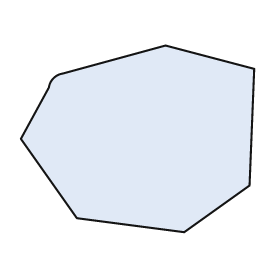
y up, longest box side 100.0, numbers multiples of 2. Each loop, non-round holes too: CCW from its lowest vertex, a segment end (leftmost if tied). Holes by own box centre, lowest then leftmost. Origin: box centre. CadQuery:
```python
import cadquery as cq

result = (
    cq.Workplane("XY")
    .moveTo(20.0, -40.0)
    .lineTo(48.0, -20.0)
    .lineTo(50.0, 30.0)
    .lineTo(12.0, 40.0)
    .lineTo(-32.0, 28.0)
    .threePointArc((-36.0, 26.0), (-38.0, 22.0))
    .lineTo(-50.0, 0.0)
    .lineTo(-26.0, -34.0)
    .close()
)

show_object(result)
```